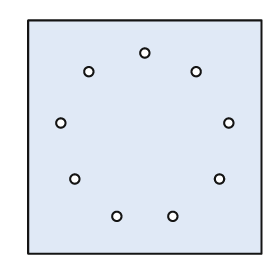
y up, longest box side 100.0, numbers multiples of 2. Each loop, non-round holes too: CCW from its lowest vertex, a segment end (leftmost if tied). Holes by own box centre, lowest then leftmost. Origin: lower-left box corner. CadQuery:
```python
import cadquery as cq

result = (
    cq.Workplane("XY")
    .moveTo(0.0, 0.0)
    .lineTo(100.0, 0.0)
    .lineTo(100.0, 100.0)
    .lineTo(0.0, 100.0)
    .close()
    .moveTo(38.0, 16.0)
    .circle(2.0)
    .moveTo(62.0, 16.0)
    .circle(2.0)
    .moveTo(20.0, 32.0)
    .circle(2.0)
    .moveTo(82.0, 32.0)
    .circle(2.0)
    .moveTo(14.0, 56.0)
    .circle(2.0)
    .moveTo(86.0, 56.0)
    .circle(2.0)
    .moveTo(26.0, 78.0)
    .circle(2.0)
    .moveTo(72.0, 78.0)
    .circle(2.0)
    .moveTo(50.0, 86.0)
    .circle(2.0)
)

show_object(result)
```